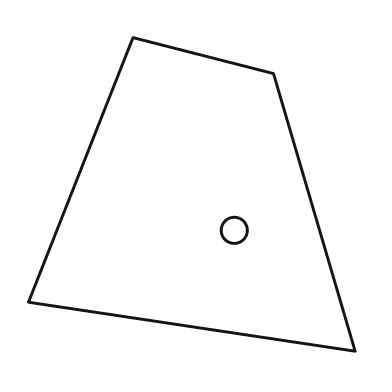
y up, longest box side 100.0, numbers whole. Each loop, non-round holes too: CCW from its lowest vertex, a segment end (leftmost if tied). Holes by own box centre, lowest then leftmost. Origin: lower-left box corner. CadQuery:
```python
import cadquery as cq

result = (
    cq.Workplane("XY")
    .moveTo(100.0, 0.0)
    .lineTo(75.0, 85.0)
    .lineTo(32.0, 96.0)
    .lineTo(0.0, 15.0)
    .close()
    .moveTo(63.0, 37.0)
    .circle(4.0)
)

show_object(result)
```